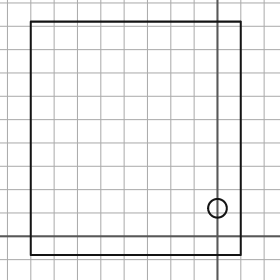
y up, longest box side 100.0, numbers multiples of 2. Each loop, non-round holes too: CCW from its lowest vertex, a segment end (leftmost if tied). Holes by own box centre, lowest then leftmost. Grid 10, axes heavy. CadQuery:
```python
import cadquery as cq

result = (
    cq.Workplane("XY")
    .moveTo(-80.0, -8.0)
    .lineTo(10.0, -8.0)
    .lineTo(10.0, 92.0)
    .lineTo(-80.0, 92.0)
    .close()
    .moveTo(0.0, 12.0)
    .circle(4.0)
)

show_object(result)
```